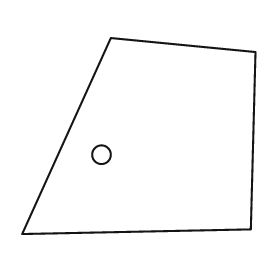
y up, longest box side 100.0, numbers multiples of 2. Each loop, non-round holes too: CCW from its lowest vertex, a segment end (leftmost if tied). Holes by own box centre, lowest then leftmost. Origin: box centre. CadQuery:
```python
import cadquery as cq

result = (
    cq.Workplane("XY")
    .moveTo(-50.0, -42.0)
    .lineTo(48.0, -40.0)
    .lineTo(50.0, 36.0)
    .lineTo(-12.0, 42.0)
    .close()
    .moveTo(-16.0, -8.0)
    .circle(4.0)
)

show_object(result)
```